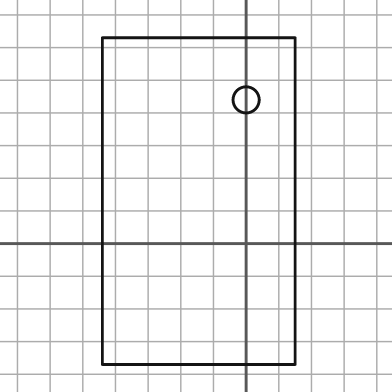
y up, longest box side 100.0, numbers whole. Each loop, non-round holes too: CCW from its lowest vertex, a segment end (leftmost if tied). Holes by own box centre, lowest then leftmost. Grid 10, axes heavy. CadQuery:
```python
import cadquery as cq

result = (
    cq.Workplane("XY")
    .moveTo(-44.0, -37.0)
    .lineTo(15.0, -37.0)
    .lineTo(15.0, 63.0)
    .lineTo(-44.0, 63.0)
    .close()
    .moveTo(0.0, 44.0)
    .circle(4.0)
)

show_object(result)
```